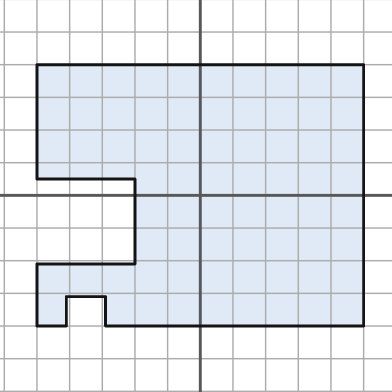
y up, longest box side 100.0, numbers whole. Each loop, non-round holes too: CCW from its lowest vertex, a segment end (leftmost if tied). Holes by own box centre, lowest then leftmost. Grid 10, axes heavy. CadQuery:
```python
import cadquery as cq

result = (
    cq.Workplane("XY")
    .moveTo(-50.0, -40.0)
    .lineTo(-41.0, -40.0)
    .lineTo(-41.0, -31.0)
    .lineTo(-29.0, -31.0)
    .lineTo(-29.0, -40.0)
    .lineTo(50.0, -40.0)
    .lineTo(50.0, 40.0)
    .lineTo(-50.0, 40.0)
    .lineTo(-50.0, 5.0)
    .lineTo(-20.0, 5.0)
    .lineTo(-20.0, -21.0)
    .lineTo(-50.0, -21.0)
    .close()
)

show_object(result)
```